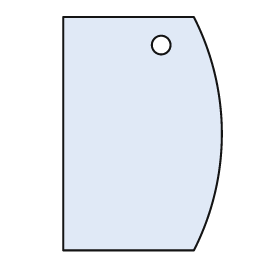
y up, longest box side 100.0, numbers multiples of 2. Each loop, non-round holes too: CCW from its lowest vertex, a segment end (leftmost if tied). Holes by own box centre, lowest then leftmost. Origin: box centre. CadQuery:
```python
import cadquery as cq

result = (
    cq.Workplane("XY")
    .moveTo(-34.0, -50.0)
    .lineTo(22.0, -50.0)
    .threePointArc((34.0, 0.0), (22.0, 50.0))
    .lineTo(-34.0, 50.0)
    .close()
    .moveTo(8.0, 38.0)
    .circle(4.0)
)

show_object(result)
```